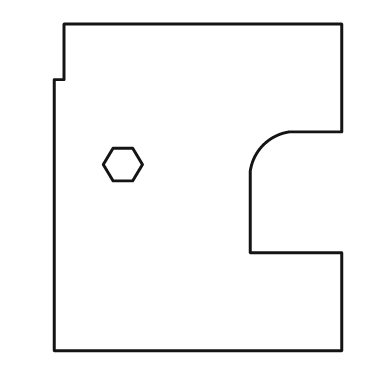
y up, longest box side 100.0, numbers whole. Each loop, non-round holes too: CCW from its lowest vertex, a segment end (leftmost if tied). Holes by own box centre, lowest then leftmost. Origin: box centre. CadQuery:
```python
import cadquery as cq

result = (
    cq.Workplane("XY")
    .moveTo(-44.0, -50.0)
    .lineTo(44.0, -50.0)
    .lineTo(44.0, -20.0)
    .lineTo(16.0, -20.0)
    .lineTo(16.0, 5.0)
    .threePointArc((20.0, 13.0), (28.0, 17.0))
    .lineTo(44.0, 17.0)
    .lineTo(44.0, 50.0)
    .lineTo(-41.0, 50.0)
    .lineTo(-41.0, 33.0)
    .lineTo(-44.0, 33.0)
    .close()
    .moveTo(-26.0, 2.0)
    .lineTo(-20.0, 2.0)
    .lineTo(-17.0, 7.0)
    .lineTo(-20.0, 12.0)
    .lineTo(-26.0, 12.0)
    .lineTo(-29.0, 7.0)
    .close()
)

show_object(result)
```